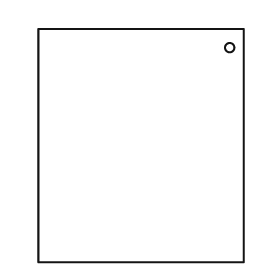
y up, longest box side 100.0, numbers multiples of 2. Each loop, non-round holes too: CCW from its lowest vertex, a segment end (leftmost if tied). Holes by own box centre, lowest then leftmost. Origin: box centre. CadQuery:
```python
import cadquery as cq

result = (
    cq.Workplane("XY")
    .moveTo(-44.0, -50.0)
    .lineTo(44.0, -50.0)
    .lineTo(44.0, 50.0)
    .lineTo(-44.0, 50.0)
    .close()
    .moveTo(38.0, 42.0)
    .circle(2.0)
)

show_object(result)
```